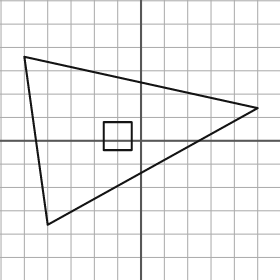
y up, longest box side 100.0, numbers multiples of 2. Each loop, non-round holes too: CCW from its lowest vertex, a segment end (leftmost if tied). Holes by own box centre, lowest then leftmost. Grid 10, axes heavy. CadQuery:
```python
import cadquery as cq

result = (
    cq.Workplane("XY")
    .moveTo(-40.0, -36.0)
    .lineTo(50.0, 14.0)
    .lineTo(-50.0, 36.0)
    .close()
    .moveTo(-16.0, -4.0)
    .lineTo(-4.0, -4.0)
    .lineTo(-4.0, 8.0)
    .lineTo(-16.0, 8.0)
    .close()
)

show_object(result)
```